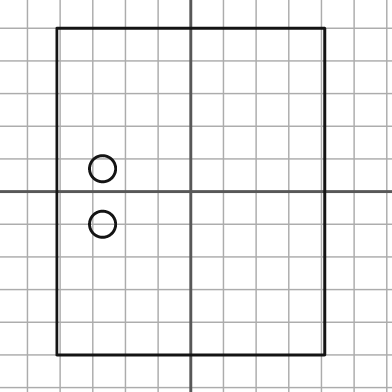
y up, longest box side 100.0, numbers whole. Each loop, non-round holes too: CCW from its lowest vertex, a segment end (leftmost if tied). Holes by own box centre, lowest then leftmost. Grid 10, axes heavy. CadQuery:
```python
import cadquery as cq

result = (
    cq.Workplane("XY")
    .moveTo(-41.0, -50.0)
    .lineTo(41.0, -50.0)
    .lineTo(41.0, 50.0)
    .lineTo(-41.0, 50.0)
    .close()
    .moveTo(-27.0, -10.0)
    .circle(4.0)
    .moveTo(-27.0, 7.0)
    .circle(4.0)
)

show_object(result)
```